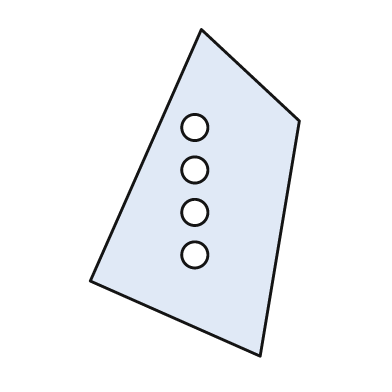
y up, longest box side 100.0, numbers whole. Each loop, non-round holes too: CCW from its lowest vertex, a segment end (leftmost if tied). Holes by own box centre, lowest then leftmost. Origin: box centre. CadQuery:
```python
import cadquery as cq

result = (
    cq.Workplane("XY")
    .moveTo(20.0, -50.0)
    .lineTo(32.0, 22.0)
    .lineTo(2.0, 50.0)
    .lineTo(-32.0, -27.0)
    .close()
    .moveTo(0.0, -19.0)
    .circle(4.0)
    .moveTo(0.0, -6.0)
    .circle(4.0)
    .moveTo(0.0, 7.0)
    .circle(4.0)
    .moveTo(0.0, 20.0)
    .circle(4.0)
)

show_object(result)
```